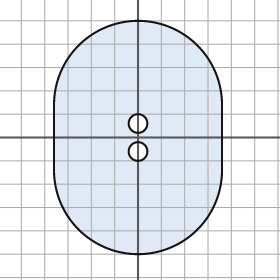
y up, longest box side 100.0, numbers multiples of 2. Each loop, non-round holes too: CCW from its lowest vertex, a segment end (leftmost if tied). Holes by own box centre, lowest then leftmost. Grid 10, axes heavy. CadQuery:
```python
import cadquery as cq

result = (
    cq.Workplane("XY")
    .moveTo(-36.0, -14.0)
    .threePointArc((0.0, -50.0), (36.0, -14.0))
    .lineTo(36.0, 14.0)
    .threePointArc((0.0, 50.0), (-36.0, 14.0))
    .close()
    .moveTo(0.0, -6.0)
    .circle(4.0)
    .moveTo(0.0, 6.0)
    .circle(4.0)
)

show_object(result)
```